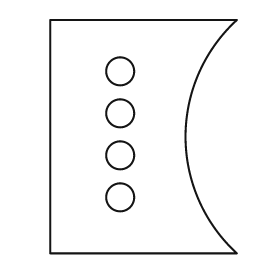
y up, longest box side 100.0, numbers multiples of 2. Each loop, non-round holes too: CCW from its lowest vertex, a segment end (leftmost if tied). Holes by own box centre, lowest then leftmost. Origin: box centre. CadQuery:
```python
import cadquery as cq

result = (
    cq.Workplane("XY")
    .moveTo(-40.0, -50.0)
    .lineTo(40.0, -50.0)
    .threePointArc((18.0, 0.0), (40.0, 50.0))
    .lineTo(-40.0, 50.0)
    .close()
    .moveTo(-10.0, -26.0)
    .circle(6.0)
    .moveTo(-10.0, -8.0)
    .circle(6.0)
    .moveTo(-10.0, 10.0)
    .circle(6.0)
    .moveTo(-10.0, 28.0)
    .circle(6.0)
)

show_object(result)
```